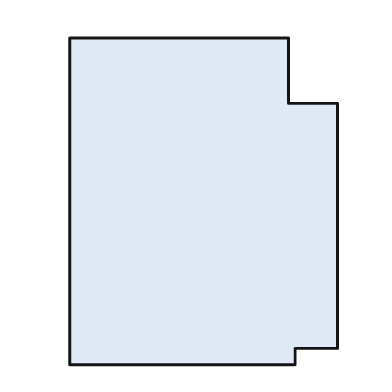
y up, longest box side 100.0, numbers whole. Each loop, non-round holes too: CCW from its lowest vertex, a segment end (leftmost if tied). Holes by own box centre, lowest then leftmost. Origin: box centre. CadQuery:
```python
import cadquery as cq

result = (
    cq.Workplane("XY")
    .moveTo(-41.0, -50.0)
    .lineTo(28.0, -50.0)
    .lineTo(28.0, -45.0)
    .lineTo(41.0, -45.0)
    .lineTo(41.0, 30.0)
    .lineTo(26.0, 30.0)
    .lineTo(26.0, 50.0)
    .lineTo(-41.0, 50.0)
    .close()
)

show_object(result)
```